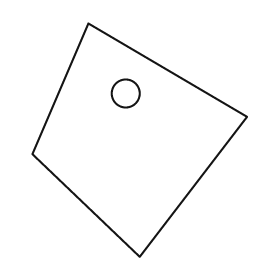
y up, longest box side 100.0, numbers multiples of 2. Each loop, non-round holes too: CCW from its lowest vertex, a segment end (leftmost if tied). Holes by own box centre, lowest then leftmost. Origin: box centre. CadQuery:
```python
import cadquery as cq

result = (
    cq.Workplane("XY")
    .moveTo(0.0, -50.0)
    .lineTo(46.0, 10.0)
    .lineTo(-22.0, 50.0)
    .lineTo(-46.0, -6.0)
    .close()
    .moveTo(-6.0, 20.0)
    .circle(6.0)
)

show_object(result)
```